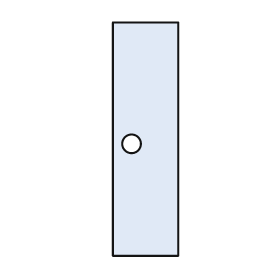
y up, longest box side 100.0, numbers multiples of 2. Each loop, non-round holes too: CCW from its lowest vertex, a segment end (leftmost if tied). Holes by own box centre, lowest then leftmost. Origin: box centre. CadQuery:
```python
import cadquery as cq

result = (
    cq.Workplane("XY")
    .moveTo(-14.0, -50.0)
    .lineTo(14.0, -50.0)
    .lineTo(14.0, 50.0)
    .lineTo(-14.0, 50.0)
    .close()
    .moveTo(-6.0, -2.0)
    .circle(4.0)
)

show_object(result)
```